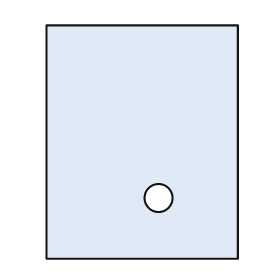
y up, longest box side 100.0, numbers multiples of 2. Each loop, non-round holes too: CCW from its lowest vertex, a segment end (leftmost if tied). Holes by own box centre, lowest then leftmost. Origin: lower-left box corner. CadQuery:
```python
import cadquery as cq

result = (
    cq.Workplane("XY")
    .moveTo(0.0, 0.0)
    .lineTo(82.0, 0.0)
    .lineTo(82.0, 100.0)
    .lineTo(0.0, 100.0)
    .close()
    .moveTo(48.0, 26.0)
    .circle(6.0)
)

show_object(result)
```